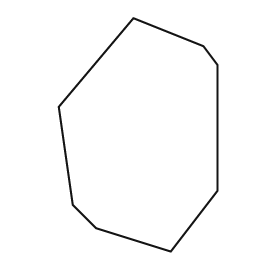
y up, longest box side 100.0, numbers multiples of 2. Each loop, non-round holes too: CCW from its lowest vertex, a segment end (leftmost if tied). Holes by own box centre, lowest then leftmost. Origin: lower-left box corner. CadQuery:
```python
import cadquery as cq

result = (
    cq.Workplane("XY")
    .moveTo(48.0, 0.0)
    .lineTo(68.0, 26.0)
    .lineTo(68.0, 80.0)
    .lineTo(62.0, 88.0)
    .lineTo(32.0, 100.0)
    .lineTo(0.0, 62.0)
    .lineTo(6.0, 20.0)
    .lineTo(16.0, 10.0)
    .close()
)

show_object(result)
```